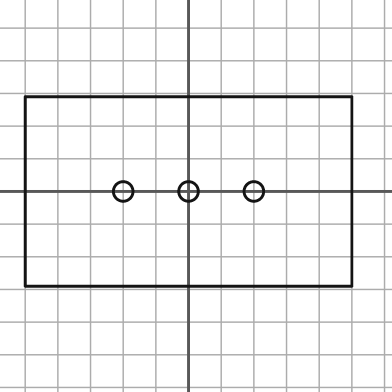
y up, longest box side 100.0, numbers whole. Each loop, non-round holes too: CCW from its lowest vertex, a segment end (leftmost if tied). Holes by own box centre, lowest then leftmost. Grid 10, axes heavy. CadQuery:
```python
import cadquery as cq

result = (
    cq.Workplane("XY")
    .moveTo(-50.0, -29.0)
    .lineTo(50.0, -29.0)
    .lineTo(50.0, 29.0)
    .lineTo(-50.0, 29.0)
    .close()
    .moveTo(-20.0, 0.0)
    .circle(3.0)
    .moveTo(0.0, 0.0)
    .circle(3.0)
    .moveTo(20.0, 0.0)
    .circle(3.0)
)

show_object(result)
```